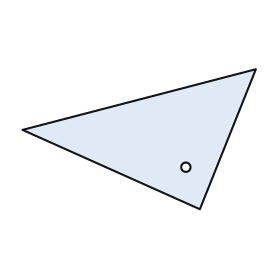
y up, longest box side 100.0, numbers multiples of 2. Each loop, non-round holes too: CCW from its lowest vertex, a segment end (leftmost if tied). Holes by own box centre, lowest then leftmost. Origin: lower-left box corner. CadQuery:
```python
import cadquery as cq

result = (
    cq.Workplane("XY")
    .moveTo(76.0, 0.0)
    .lineTo(100.0, 60.0)
    .lineTo(0.0, 34.0)
    .close()
    .moveTo(70.0, 18.0)
    .circle(2.0)
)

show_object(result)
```